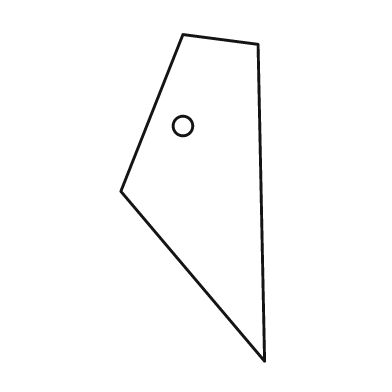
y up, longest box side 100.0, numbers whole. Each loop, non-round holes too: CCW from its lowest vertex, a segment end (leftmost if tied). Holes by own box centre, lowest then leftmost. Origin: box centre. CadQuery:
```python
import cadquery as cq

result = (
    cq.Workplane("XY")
    .moveTo(22.0, -50.0)
    .lineTo(20.0, 47.0)
    .lineTo(-3.0, 50.0)
    .lineTo(-22.0, 2.0)
    .close()
    .moveTo(-3.0, 22.0)
    .circle(3.0)
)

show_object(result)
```